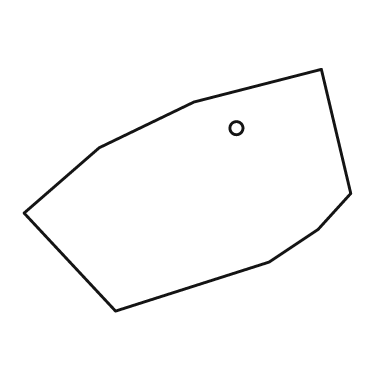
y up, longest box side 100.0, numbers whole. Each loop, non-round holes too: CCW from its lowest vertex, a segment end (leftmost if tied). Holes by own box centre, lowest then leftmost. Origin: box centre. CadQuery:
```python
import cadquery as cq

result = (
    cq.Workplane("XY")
    .moveTo(-22.0, -37.0)
    .lineTo(25.0, -22.0)
    .lineTo(40.0, -12.0)
    .lineTo(50.0, -1.0)
    .lineTo(41.0, 37.0)
    .lineTo(2.0, 27.0)
    .lineTo(-27.0, 13.0)
    .lineTo(-50.0, -7.0)
    .close()
    .moveTo(15.0, 19.0)
    .circle(2.0)
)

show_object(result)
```